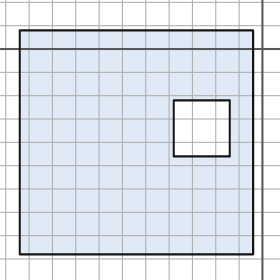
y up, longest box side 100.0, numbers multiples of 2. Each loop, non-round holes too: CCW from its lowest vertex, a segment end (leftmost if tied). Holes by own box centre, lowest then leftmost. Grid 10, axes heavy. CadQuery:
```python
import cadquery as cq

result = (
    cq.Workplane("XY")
    .moveTo(-104.0, -88.0)
    .lineTo(-4.0, -88.0)
    .lineTo(-4.0, 8.0)
    .lineTo(-104.0, 8.0)
    .close()
    .moveTo(-38.0, -46.0)
    .lineTo(-14.0, -46.0)
    .lineTo(-14.0, -22.0)
    .lineTo(-38.0, -22.0)
    .close()
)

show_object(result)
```